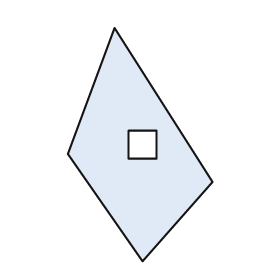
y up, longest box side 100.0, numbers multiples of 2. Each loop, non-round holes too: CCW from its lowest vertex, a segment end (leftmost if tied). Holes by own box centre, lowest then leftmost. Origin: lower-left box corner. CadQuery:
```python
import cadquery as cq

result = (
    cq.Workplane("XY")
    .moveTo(32.0, 0.0)
    .lineTo(62.0, 34.0)
    .lineTo(20.0, 100.0)
    .lineTo(0.0, 46.0)
    .close()
    .moveTo(26.0, 44.0)
    .lineTo(38.0, 44.0)
    .lineTo(38.0, 56.0)
    .lineTo(26.0, 56.0)
    .close()
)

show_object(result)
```